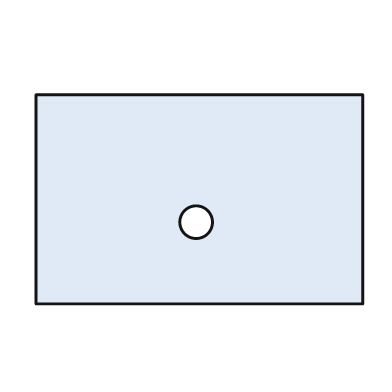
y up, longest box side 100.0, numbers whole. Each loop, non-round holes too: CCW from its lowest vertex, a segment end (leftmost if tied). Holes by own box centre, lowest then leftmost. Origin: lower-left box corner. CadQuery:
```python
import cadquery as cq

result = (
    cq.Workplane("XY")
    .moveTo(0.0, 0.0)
    .lineTo(100.0, 0.0)
    .lineTo(100.0, 64.0)
    .lineTo(0.0, 64.0)
    .close()
    .moveTo(49.0, 25.0)
    .circle(5.0)
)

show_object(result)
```